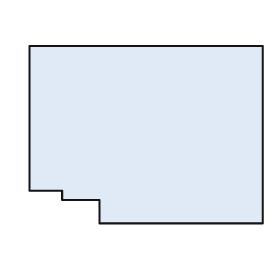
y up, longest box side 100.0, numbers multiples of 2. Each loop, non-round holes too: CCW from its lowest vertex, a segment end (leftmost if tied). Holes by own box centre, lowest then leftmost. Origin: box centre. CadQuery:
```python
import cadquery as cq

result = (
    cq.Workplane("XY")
    .moveTo(-20.0, -38.0)
    .lineTo(50.0, -38.0)
    .lineTo(50.0, 38.0)
    .lineTo(-50.0, 38.0)
    .lineTo(-50.0, -24.0)
    .lineTo(-36.0, -24.0)
    .lineTo(-36.0, -28.0)
    .lineTo(-20.0, -28.0)
    .close()
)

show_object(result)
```